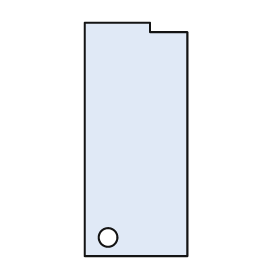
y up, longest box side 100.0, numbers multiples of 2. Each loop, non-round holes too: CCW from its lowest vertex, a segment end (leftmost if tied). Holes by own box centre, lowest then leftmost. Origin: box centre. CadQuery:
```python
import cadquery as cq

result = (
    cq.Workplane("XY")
    .moveTo(-22.0, -50.0)
    .lineTo(22.0, -50.0)
    .lineTo(22.0, 46.0)
    .lineTo(6.0, 46.0)
    .lineTo(6.0, 50.0)
    .lineTo(-22.0, 50.0)
    .close()
    .moveTo(-12.0, -42.0)
    .circle(4.0)
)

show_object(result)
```